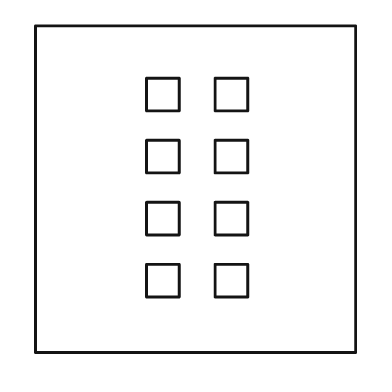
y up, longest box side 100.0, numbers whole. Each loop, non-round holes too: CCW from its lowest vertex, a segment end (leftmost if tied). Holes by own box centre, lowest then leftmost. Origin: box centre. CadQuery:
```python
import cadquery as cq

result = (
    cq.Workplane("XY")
    .moveTo(-49.0, -50.0)
    .lineTo(49.0, -50.0)
    .lineTo(49.0, 50.0)
    .lineTo(-49.0, 50.0)
    .close()
    .moveTo(-15.0, -33.0)
    .lineTo(-5.0, -33.0)
    .lineTo(-5.0, -23.0)
    .lineTo(-15.0, -23.0)
    .close()
    .moveTo(6.0, -33.0)
    .lineTo(16.0, -33.0)
    .lineTo(16.0, -23.0)
    .lineTo(6.0, -23.0)
    .close()
    .moveTo(-15.0, -14.0)
    .lineTo(-5.0, -14.0)
    .lineTo(-5.0, -4.0)
    .lineTo(-15.0, -4.0)
    .close()
    .moveTo(6.0, -14.0)
    .lineTo(16.0, -14.0)
    .lineTo(16.0, -4.0)
    .lineTo(6.0, -4.0)
    .close()
    .moveTo(-15.0, 5.0)
    .lineTo(-5.0, 5.0)
    .lineTo(-5.0, 15.0)
    .lineTo(-15.0, 15.0)
    .close()
    .moveTo(6.0, 5.0)
    .lineTo(16.0, 5.0)
    .lineTo(16.0, 15.0)
    .lineTo(6.0, 15.0)
    .close()
    .moveTo(-15.0, 24.0)
    .lineTo(-5.0, 24.0)
    .lineTo(-5.0, 34.0)
    .lineTo(-15.0, 34.0)
    .close()
    .moveTo(6.0, 24.0)
    .lineTo(16.0, 24.0)
    .lineTo(16.0, 34.0)
    .lineTo(6.0, 34.0)
    .close()
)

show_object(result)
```